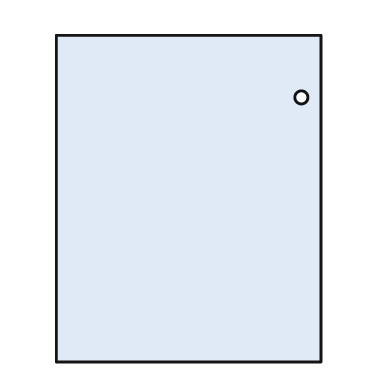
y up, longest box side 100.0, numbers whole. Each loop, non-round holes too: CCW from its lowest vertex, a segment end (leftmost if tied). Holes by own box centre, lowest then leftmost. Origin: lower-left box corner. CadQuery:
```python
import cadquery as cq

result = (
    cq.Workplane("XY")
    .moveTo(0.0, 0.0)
    .lineTo(81.0, 0.0)
    .lineTo(81.0, 100.0)
    .lineTo(0.0, 100.0)
    .close()
    .moveTo(75.0, 81.0)
    .circle(2.0)
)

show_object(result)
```